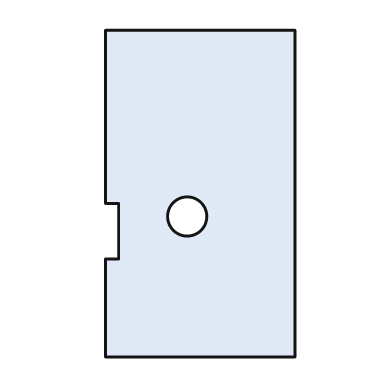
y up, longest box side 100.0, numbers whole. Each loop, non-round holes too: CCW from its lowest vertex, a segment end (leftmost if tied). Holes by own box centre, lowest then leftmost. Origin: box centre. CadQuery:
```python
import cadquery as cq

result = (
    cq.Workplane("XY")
    .moveTo(-29.0, -50.0)
    .lineTo(29.0, -50.0)
    .lineTo(29.0, 50.0)
    .lineTo(-29.0, 50.0)
    .lineTo(-29.0, -3.0)
    .lineTo(-25.0, -3.0)
    .lineTo(-25.0, -20.0)
    .lineTo(-29.0, -20.0)
    .close()
    .moveTo(-4.0, -7.0)
    .circle(6.0)
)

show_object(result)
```